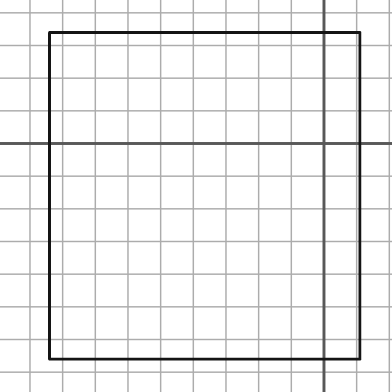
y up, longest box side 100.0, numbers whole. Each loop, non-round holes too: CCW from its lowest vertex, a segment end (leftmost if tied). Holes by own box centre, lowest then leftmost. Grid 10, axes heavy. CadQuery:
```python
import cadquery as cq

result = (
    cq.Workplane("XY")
    .moveTo(-84.0, -66.0)
    .lineTo(11.0, -66.0)
    .lineTo(11.0, 34.0)
    .lineTo(-84.0, 34.0)
    .close()
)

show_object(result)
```